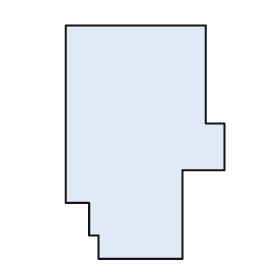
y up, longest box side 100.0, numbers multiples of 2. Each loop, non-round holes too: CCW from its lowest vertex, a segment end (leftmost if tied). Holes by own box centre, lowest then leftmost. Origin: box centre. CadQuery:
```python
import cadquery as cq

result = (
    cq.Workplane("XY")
    .moveTo(-20.0, -50.0)
    .lineTo(16.0, -50.0)
    .lineTo(16.0, -12.0)
    .lineTo(34.0, -12.0)
    .lineTo(34.0, 8.0)
    .lineTo(26.0, 8.0)
    .lineTo(26.0, 50.0)
    .lineTo(-34.0, 50.0)
    .lineTo(-34.0, -26.0)
    .lineTo(-24.0, -26.0)
    .lineTo(-24.0, -40.0)
    .lineTo(-20.0, -40.0)
    .close()
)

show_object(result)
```